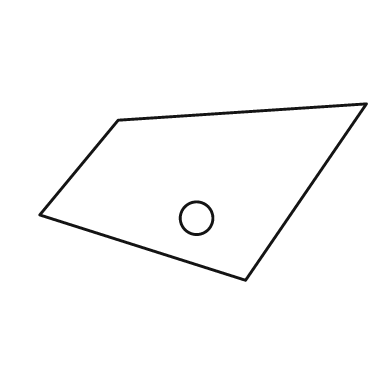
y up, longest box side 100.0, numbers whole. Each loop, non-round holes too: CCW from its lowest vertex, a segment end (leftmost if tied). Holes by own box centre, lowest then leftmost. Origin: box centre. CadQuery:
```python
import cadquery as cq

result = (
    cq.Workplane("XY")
    .moveTo(13.0, -27.0)
    .lineTo(50.0, 27.0)
    .lineTo(-26.0, 22.0)
    .lineTo(-50.0, -7.0)
    .close()
    .moveTo(-2.0, -8.0)
    .circle(5.0)
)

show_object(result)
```